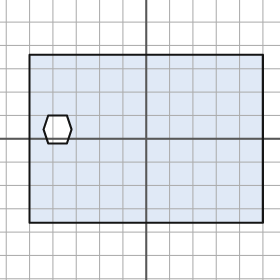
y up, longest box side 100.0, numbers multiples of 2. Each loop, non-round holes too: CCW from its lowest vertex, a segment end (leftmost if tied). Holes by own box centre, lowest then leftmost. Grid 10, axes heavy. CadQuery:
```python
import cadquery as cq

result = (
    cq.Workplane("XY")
    .moveTo(-50.0, -36.0)
    .lineTo(50.0, -36.0)
    .lineTo(50.0, 36.0)
    .lineTo(-50.0, 36.0)
    .close()
    .moveTo(-42.0, -2.0)
    .lineTo(-34.0, -2.0)
    .lineTo(-32.0, 4.0)
    .lineTo(-34.0, 10.0)
    .lineTo(-42.0, 10.0)
    .lineTo(-44.0, 4.0)
    .close()
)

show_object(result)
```